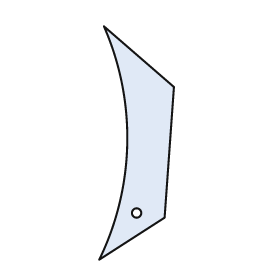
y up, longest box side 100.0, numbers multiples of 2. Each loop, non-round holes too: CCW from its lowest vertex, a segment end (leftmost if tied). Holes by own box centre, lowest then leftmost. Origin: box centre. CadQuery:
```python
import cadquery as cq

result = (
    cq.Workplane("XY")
    .moveTo(-16.0, -50.0)
    .lineTo(12.0, -32.0)
    .lineTo(16.0, 24.0)
    .lineTo(-14.0, 50.0)
    .threePointArc((-4.0, 0.0), (-16.0, -50.0))
    .close()
    .moveTo(0.0, -30.0)
    .circle(2.0)
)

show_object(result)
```